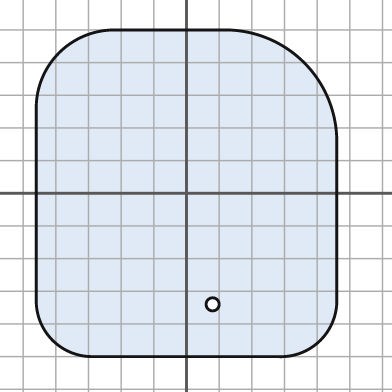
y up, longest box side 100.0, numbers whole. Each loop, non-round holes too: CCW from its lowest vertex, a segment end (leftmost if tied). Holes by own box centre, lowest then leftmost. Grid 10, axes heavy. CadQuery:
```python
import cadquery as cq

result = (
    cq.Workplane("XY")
    .moveTo(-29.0, -50.0)
    .lineTo(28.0, -50.0)
    .threePointArc((41.0, -45.0), (46.0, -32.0))
    .lineTo(46.0, 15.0)
    .threePointArc((36.0, 40.0), (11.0, 50.0))
    .lineTo(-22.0, 50.0)
    .threePointArc((-39.0, 43.0), (-46.0, 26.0))
    .lineTo(-46.0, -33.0)
    .threePointArc((-41.0, -45.0), (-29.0, -50.0))
    .close()
    .moveTo(8.0, -34.0)
    .circle(2.0)
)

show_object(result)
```